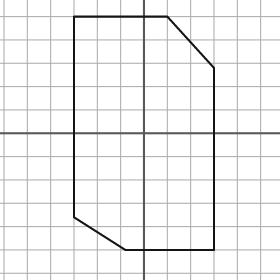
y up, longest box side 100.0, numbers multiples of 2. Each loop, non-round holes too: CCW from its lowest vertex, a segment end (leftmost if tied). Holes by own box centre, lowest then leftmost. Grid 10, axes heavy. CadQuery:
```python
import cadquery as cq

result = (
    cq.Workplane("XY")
    .moveTo(-8.0, -50.0)
    .lineTo(30.0, -50.0)
    .lineTo(30.0, 28.0)
    .lineTo(10.0, 50.0)
    .lineTo(-30.0, 50.0)
    .lineTo(-30.0, -36.0)
    .close()
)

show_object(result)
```